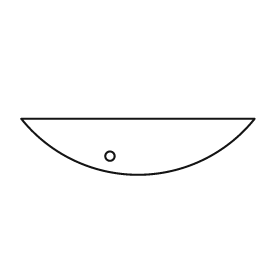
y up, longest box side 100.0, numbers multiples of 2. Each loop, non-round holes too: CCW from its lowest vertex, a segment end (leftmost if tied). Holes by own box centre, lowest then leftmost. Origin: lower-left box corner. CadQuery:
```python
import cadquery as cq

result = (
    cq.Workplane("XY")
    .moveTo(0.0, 24.0)
    .threePointArc((50.0, 0.0), (100.0, 24.0))
    .close()
    .moveTo(38.0, 8.0)
    .circle(2.0)
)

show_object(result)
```